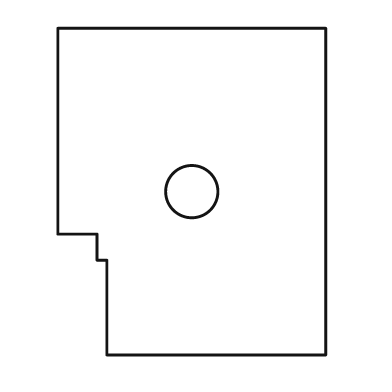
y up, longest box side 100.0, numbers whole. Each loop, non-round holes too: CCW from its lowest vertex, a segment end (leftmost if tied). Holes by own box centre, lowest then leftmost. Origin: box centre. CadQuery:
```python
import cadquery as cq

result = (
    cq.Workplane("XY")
    .moveTo(-26.0, -50.0)
    .lineTo(41.0, -50.0)
    .lineTo(41.0, 50.0)
    .lineTo(-41.0, 50.0)
    .lineTo(-41.0, -13.0)
    .lineTo(-29.0, -13.0)
    .lineTo(-29.0, -21.0)
    .lineTo(-26.0, -21.0)
    .close()
    .moveTo(0.0, 0.0)
    .circle(8.0)
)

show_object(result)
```